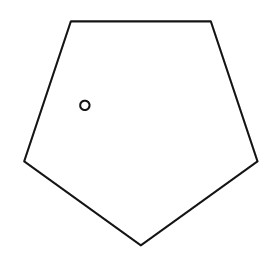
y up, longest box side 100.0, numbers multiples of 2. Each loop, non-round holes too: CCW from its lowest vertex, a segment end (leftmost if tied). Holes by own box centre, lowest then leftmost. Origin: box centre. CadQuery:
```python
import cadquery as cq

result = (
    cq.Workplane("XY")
    .moveTo(0.0, -48.0)
    .lineTo(50.0, -12.0)
    .lineTo(30.0, 48.0)
    .lineTo(-30.0, 48.0)
    .lineTo(-50.0, -12.0)
    .close()
    .moveTo(-24.0, 12.0)
    .circle(2.0)
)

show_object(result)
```